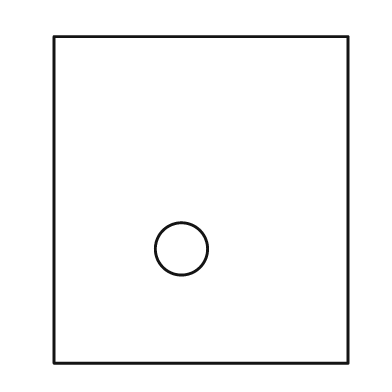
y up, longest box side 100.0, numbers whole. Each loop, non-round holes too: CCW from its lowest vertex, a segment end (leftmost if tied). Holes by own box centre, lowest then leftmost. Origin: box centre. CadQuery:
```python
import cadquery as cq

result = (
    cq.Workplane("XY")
    .moveTo(-45.0, -50.0)
    .lineTo(45.0, -50.0)
    .lineTo(45.0, 50.0)
    .lineTo(-45.0, 50.0)
    .close()
    .moveTo(-6.0, -15.0)
    .circle(8.0)
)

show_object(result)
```